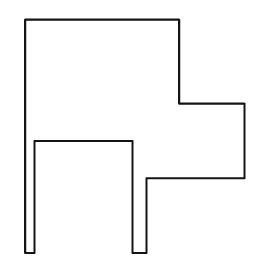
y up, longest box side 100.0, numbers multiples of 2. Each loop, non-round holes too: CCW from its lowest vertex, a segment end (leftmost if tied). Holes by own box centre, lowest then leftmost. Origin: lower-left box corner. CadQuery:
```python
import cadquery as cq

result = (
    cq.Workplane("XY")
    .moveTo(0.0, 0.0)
    .lineTo(4.0, 0.0)
    .lineTo(4.0, 48.0)
    .lineTo(46.0, 48.0)
    .lineTo(46.0, 0.0)
    .lineTo(52.0, 0.0)
    .lineTo(52.0, 32.0)
    .lineTo(94.0, 32.0)
    .lineTo(94.0, 64.0)
    .lineTo(66.0, 64.0)
    .lineTo(66.0, 100.0)
    .lineTo(0.0, 100.0)
    .close()
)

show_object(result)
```